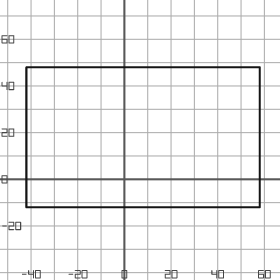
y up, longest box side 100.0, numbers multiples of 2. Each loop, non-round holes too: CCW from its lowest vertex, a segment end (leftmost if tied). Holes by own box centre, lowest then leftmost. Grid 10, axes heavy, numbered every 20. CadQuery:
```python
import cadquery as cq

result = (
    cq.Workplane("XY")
    .moveTo(-42.0, -12.0)
    .lineTo(58.0, -12.0)
    .lineTo(58.0, 48.0)
    .lineTo(-42.0, 48.0)
    .close()
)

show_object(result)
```